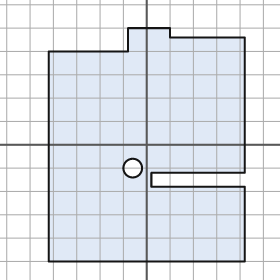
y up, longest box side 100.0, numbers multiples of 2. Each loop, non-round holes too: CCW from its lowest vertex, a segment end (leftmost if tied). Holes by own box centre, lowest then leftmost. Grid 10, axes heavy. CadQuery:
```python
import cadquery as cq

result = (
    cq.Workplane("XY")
    .moveTo(-42.0, -50.0)
    .lineTo(42.0, -50.0)
    .lineTo(42.0, -18.0)
    .lineTo(2.0, -18.0)
    .lineTo(2.0, -12.0)
    .lineTo(42.0, -12.0)
    .lineTo(42.0, 46.0)
    .lineTo(10.0, 46.0)
    .lineTo(10.0, 50.0)
    .lineTo(-8.0, 50.0)
    .lineTo(-8.0, 40.0)
    .lineTo(-42.0, 40.0)
    .close()
    .moveTo(-6.0, -10.0)
    .circle(4.0)
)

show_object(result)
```